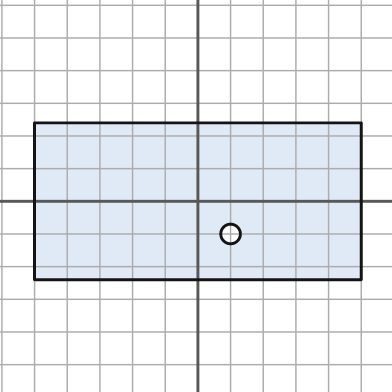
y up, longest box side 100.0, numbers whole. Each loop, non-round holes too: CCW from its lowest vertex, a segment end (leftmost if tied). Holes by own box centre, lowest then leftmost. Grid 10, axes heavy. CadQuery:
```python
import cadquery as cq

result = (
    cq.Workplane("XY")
    .moveTo(-50.0, -24.0)
    .lineTo(50.0, -24.0)
    .lineTo(50.0, 24.0)
    .lineTo(-50.0, 24.0)
    .close()
    .moveTo(10.0, -10.0)
    .circle(3.0)
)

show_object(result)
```